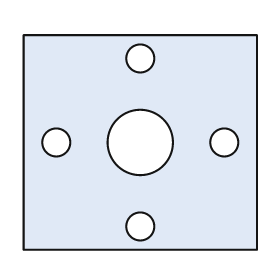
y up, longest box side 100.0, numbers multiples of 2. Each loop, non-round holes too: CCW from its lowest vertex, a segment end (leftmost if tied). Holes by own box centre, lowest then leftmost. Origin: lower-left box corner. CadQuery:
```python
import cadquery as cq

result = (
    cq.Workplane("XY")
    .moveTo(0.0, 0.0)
    .lineTo(100.0, 0.0)
    .lineTo(100.0, 92.0)
    .lineTo(0.0, 92.0)
    .close()
    .moveTo(50.0, 10.0)
    .circle(6.0)
    .moveTo(14.0, 46.0)
    .circle(6.0)
    .moveTo(50.0, 46.0)
    .circle(14.0)
    .moveTo(86.0, 46.0)
    .circle(6.0)
    .moveTo(50.0, 82.0)
    .circle(6.0)
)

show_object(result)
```